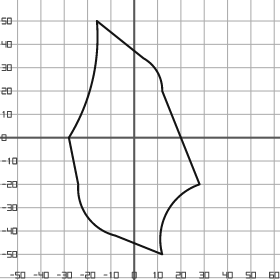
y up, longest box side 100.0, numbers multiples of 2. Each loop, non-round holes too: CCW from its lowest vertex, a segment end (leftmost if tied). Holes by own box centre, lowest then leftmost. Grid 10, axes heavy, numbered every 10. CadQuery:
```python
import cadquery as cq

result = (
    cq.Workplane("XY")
    .moveTo(12.0, -50.0)
    .threePointArc((14.0, -32.0), (28.0, -20.0))
    .lineTo(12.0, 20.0)
    .threePointArc((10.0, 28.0), (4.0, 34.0))
    .lineTo(-16.0, 50.0)
    .threePointArc((-18.0, 24.0), (-28.0, 0.0))
    .lineTo(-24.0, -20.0)
    .threePointArc((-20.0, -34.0), (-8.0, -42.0))
    .close()
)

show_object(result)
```